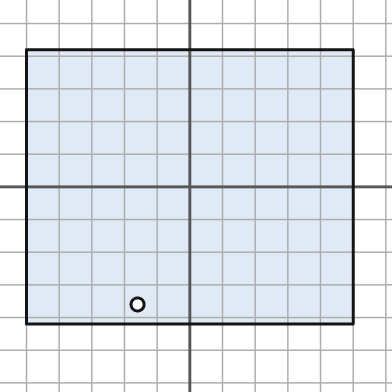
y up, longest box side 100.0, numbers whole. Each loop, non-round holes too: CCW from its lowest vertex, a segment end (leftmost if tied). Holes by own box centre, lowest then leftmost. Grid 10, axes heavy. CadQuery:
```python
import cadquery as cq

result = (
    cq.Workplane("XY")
    .moveTo(-50.0, -42.0)
    .lineTo(50.0, -42.0)
    .lineTo(50.0, 42.0)
    .lineTo(-50.0, 42.0)
    .close()
    .moveTo(-16.0, -36.0)
    .circle(2.0)
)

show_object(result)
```